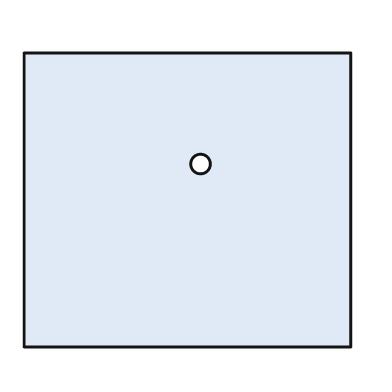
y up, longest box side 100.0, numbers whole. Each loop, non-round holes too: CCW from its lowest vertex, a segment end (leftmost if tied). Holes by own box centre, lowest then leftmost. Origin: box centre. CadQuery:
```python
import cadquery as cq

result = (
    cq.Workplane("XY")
    .moveTo(-50.0, -45.0)
    .lineTo(50.0, -45.0)
    .lineTo(50.0, 45.0)
    .lineTo(-50.0, 45.0)
    .close()
    .moveTo(4.0, 11.0)
    .circle(3.0)
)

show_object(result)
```